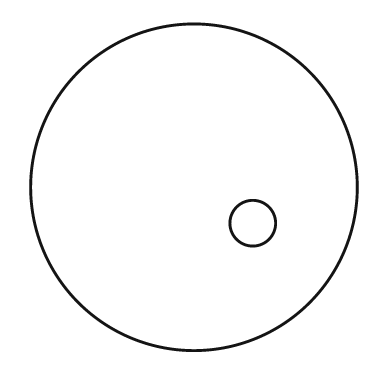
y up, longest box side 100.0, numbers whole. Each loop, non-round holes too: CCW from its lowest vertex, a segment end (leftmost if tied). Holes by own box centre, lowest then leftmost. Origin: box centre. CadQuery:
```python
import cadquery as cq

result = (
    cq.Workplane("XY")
    .moveTo(0.0, 0.0)
    .circle(50.0)
    .moveTo(18.0, -11.0)
    .circle(7.0)
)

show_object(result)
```